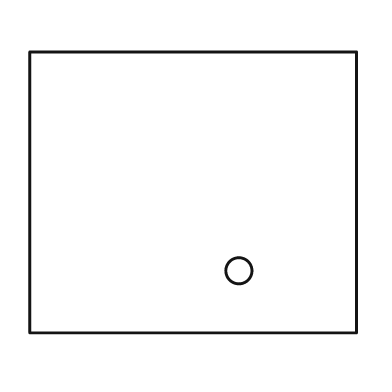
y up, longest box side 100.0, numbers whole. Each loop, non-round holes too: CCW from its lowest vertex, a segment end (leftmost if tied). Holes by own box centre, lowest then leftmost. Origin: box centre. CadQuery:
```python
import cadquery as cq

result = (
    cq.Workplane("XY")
    .moveTo(-50.0, -43.0)
    .lineTo(50.0, -43.0)
    .lineTo(50.0, 43.0)
    .lineTo(-50.0, 43.0)
    .close()
    .moveTo(14.0, -24.0)
    .circle(4.0)
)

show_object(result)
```